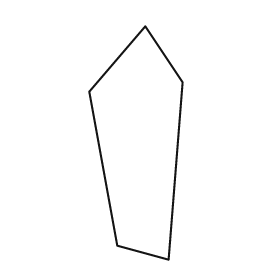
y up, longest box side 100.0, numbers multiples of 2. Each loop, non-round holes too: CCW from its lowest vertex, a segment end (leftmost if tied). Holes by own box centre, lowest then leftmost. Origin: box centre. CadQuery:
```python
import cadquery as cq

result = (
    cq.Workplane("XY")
    .moveTo(14.0, -50.0)
    .lineTo(20.0, 26.0)
    .lineTo(4.0, 50.0)
    .lineTo(-20.0, 22.0)
    .lineTo(-8.0, -44.0)
    .close()
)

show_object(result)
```